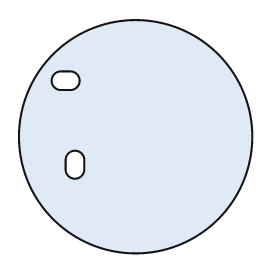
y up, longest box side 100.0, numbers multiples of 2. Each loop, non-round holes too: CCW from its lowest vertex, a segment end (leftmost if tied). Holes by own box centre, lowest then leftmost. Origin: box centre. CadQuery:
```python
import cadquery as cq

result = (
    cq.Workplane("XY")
    .moveTo(0.0, 0.0)
    .circle(50.0)
    .moveTo(-30.0, -14.0)
    .threePointArc((-26.0, -18.0), (-22.0, -14.0))
    .lineTo(-22.0, -10.0)
    .threePointArc((-26.0, -6.0), (-30.0, -10.0))
    .close()
    .moveTo(-32.0, 20.0)
    .lineTo(-28.0, 20.0)
    .threePointArc((-24.0, 24.0), (-28.0, 28.0))
    .lineTo(-32.0, 28.0)
    .threePointArc((-36.0, 24.0), (-32.0, 20.0))
    .close()
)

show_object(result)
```